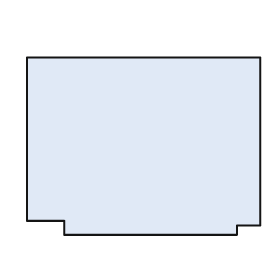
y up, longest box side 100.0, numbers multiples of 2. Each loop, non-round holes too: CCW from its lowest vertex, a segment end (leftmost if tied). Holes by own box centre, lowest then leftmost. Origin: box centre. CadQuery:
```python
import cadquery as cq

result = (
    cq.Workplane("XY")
    .moveTo(-34.0, -38.0)
    .lineTo(40.0, -38.0)
    .lineTo(40.0, -34.0)
    .lineTo(50.0, -34.0)
    .lineTo(50.0, 38.0)
    .lineTo(-50.0, 38.0)
    .lineTo(-50.0, -32.0)
    .lineTo(-34.0, -32.0)
    .close()
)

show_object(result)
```